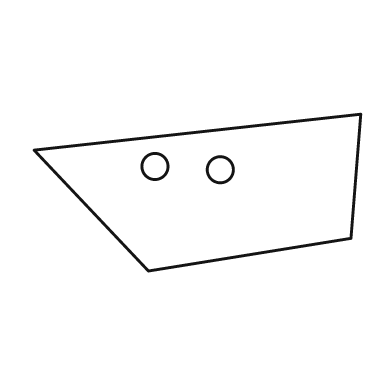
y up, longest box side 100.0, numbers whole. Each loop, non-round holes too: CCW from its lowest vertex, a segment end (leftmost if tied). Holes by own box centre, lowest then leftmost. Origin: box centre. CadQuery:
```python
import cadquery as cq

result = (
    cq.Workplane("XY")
    .moveTo(-15.0, -24.0)
    .lineTo(47.0, -14.0)
    .lineTo(50.0, 24.0)
    .lineTo(-50.0, 13.0)
    .close()
    .moveTo(7.0, 7.0)
    .circle(4.0)
    .moveTo(-13.0, 8.0)
    .circle(4.0)
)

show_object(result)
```